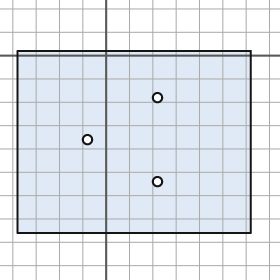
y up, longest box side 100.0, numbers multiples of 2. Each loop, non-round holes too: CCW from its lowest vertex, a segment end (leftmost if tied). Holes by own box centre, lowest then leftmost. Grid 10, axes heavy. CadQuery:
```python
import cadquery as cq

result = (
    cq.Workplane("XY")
    .moveTo(-38.0, -76.0)
    .lineTo(62.0, -76.0)
    .lineTo(62.0, 2.0)
    .lineTo(-38.0, 2.0)
    .close()
    .moveTo(22.0, -54.0)
    .circle(2.0)
    .moveTo(-8.0, -36.0)
    .circle(2.0)
    .moveTo(22.0, -18.0)
    .circle(2.0)
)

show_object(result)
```